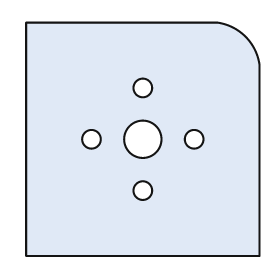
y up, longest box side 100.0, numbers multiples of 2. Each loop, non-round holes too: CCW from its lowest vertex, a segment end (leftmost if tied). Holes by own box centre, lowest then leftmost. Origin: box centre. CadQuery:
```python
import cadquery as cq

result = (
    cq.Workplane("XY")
    .moveTo(-50.0, -50.0)
    .lineTo(50.0, -50.0)
    .lineTo(50.0, 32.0)
    .threePointArc((44.0, 44.0), (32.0, 50.0))
    .lineTo(-50.0, 50.0)
    .close()
    .moveTo(0.0, -22.0)
    .circle(4.0)
    .moveTo(-22.0, 0.0)
    .circle(4.0)
    .moveTo(0.0, 0.0)
    .circle(8.0)
    .moveTo(22.0, 0.0)
    .circle(4.0)
    .moveTo(0.0, 22.0)
    .circle(4.0)
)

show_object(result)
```